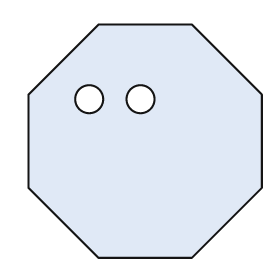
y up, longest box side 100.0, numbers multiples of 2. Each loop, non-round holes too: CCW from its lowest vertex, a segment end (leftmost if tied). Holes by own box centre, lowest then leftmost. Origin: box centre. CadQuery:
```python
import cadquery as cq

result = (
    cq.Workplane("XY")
    .moveTo(-20.0, -50.0)
    .lineTo(20.0, -50.0)
    .lineTo(50.0, -20.0)
    .lineTo(50.0, 20.0)
    .lineTo(20.0, 50.0)
    .lineTo(-20.0, 50.0)
    .lineTo(-50.0, 20.0)
    .lineTo(-50.0, -20.0)
    .close()
    .moveTo(-24.0, 18.0)
    .circle(6.0)
    .moveTo(-2.0, 18.0)
    .circle(6.0)
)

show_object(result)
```